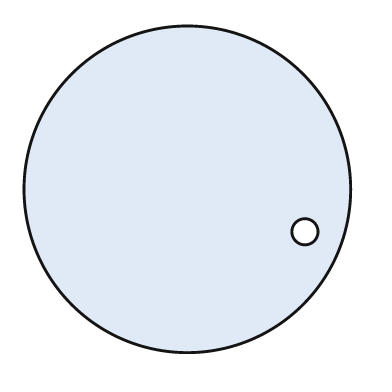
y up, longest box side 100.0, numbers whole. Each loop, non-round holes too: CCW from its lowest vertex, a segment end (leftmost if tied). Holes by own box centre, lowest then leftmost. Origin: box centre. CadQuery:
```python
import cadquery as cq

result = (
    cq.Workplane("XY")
    .moveTo(0.0, 0.0)
    .circle(50.0)
    .moveTo(36.0, -13.0)
    .circle(4.0)
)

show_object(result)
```